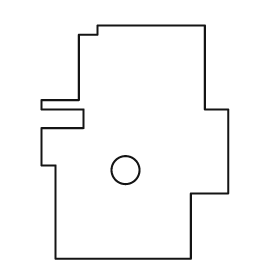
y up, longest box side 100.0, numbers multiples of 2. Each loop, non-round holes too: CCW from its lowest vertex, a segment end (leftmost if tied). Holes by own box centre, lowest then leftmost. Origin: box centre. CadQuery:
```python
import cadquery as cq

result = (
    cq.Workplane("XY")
    .moveTo(-34.0, -50.0)
    .lineTo(24.0, -50.0)
    .lineTo(24.0, -22.0)
    .lineTo(40.0, -22.0)
    .lineTo(40.0, 14.0)
    .lineTo(30.0, 14.0)
    .lineTo(30.0, 50.0)
    .lineTo(-16.0, 50.0)
    .lineTo(-16.0, 46.0)
    .lineTo(-24.0, 46.0)
    .lineTo(-24.0, 18.0)
    .lineTo(-40.0, 18.0)
    .lineTo(-40.0, 14.0)
    .lineTo(-22.0, 14.0)
    .lineTo(-22.0, 6.0)
    .lineTo(-40.0, 6.0)
    .lineTo(-40.0, -10.0)
    .lineTo(-34.0, -10.0)
    .close()
    .moveTo(-4.0, -12.0)
    .circle(6.0)
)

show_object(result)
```